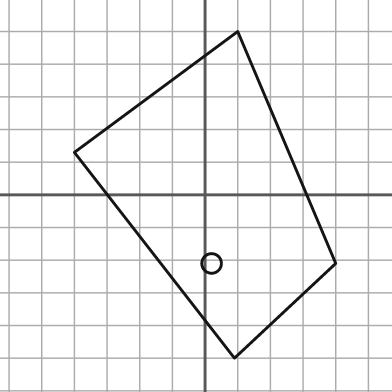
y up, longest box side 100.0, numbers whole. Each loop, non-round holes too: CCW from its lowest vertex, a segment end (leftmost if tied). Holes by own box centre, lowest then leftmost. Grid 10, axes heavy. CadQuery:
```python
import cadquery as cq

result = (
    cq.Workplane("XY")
    .moveTo(9.0, -50.0)
    .lineTo(40.0, -21.0)
    .lineTo(10.0, 50.0)
    .lineTo(-40.0, 13.0)
    .close()
    .moveTo(2.0, -21.0)
    .circle(3.0)
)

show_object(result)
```